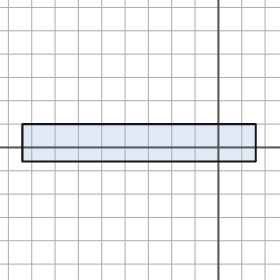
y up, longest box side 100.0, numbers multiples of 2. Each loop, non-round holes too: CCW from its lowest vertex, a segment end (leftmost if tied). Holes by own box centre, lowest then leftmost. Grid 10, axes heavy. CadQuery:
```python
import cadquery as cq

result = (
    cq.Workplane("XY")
    .moveTo(-84.0, -6.0)
    .lineTo(16.0, -6.0)
    .lineTo(16.0, 10.0)
    .lineTo(-84.0, 10.0)
    .close()
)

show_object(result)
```